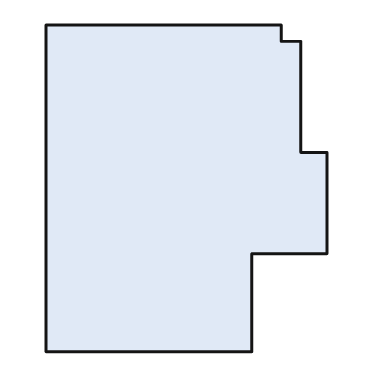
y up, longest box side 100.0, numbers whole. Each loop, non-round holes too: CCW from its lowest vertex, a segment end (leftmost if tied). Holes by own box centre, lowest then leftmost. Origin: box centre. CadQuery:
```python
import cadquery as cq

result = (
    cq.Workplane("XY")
    .moveTo(-43.0, -50.0)
    .lineTo(20.0, -50.0)
    .lineTo(20.0, -20.0)
    .lineTo(43.0, -20.0)
    .lineTo(43.0, 11.0)
    .lineTo(35.0, 11.0)
    .lineTo(35.0, 45.0)
    .lineTo(29.0, 45.0)
    .lineTo(29.0, 50.0)
    .lineTo(-43.0, 50.0)
    .close()
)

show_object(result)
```